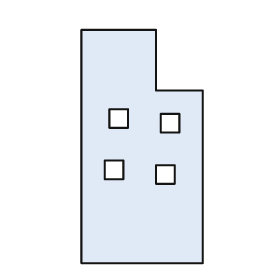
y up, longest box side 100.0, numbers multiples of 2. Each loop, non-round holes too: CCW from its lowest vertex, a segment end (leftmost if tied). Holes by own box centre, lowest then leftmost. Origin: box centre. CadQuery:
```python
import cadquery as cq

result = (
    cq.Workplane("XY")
    .moveTo(-26.0, -50.0)
    .lineTo(26.0, -50.0)
    .lineTo(26.0, 24.0)
    .lineTo(6.0, 24.0)
    .lineTo(6.0, 50.0)
    .lineTo(-26.0, 50.0)
    .close()
    .moveTo(6.0, -16.0)
    .lineTo(14.0, -16.0)
    .lineTo(14.0, -8.0)
    .lineTo(6.0, -8.0)
    .close()
    .moveTo(-16.0, -14.0)
    .lineTo(-8.0, -14.0)
    .lineTo(-8.0, -6.0)
    .lineTo(-16.0, -6.0)
    .close()
    .moveTo(8.0, 6.0)
    .lineTo(16.0, 6.0)
    .lineTo(16.0, 14.0)
    .lineTo(8.0, 14.0)
    .close()
    .moveTo(-14.0, 8.0)
    .lineTo(-6.0, 8.0)
    .lineTo(-6.0, 16.0)
    .lineTo(-14.0, 16.0)
    .close()
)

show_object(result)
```